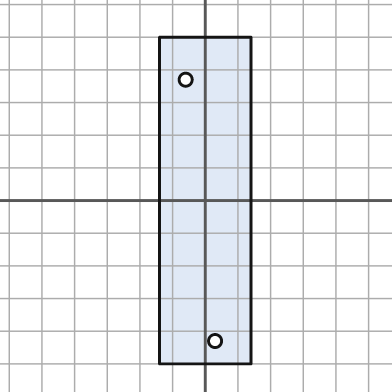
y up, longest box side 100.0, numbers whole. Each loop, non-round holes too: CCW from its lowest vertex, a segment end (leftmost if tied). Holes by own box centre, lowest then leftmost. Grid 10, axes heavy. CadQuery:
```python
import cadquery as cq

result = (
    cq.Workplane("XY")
    .moveTo(-14.0, -50.0)
    .lineTo(14.0, -50.0)
    .lineTo(14.0, 50.0)
    .lineTo(-14.0, 50.0)
    .close()
    .moveTo(3.0, -43.0)
    .circle(2.0)
    .moveTo(-6.0, 37.0)
    .circle(2.0)
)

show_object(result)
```